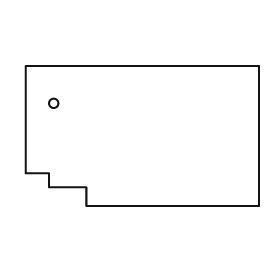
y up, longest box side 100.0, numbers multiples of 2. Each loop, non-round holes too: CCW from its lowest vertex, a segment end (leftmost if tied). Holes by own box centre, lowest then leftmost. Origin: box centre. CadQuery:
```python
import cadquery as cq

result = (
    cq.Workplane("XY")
    .moveTo(-24.0, -30.0)
    .lineTo(50.0, -30.0)
    .lineTo(50.0, 30.0)
    .lineTo(-50.0, 30.0)
    .lineTo(-50.0, -16.0)
    .lineTo(-40.0, -16.0)
    .lineTo(-40.0, -22.0)
    .lineTo(-24.0, -22.0)
    .close()
    .moveTo(-38.0, 14.0)
    .circle(2.0)
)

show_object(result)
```